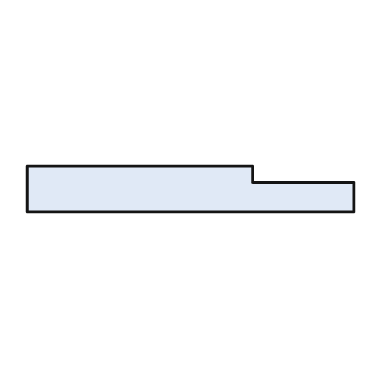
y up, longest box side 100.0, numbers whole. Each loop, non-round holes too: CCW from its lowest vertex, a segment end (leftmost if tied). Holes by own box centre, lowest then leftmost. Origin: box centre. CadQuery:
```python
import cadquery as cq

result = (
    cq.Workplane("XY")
    .moveTo(-50.0, -7.0)
    .lineTo(50.0, -7.0)
    .lineTo(50.0, 2.0)
    .lineTo(19.0, 2.0)
    .lineTo(19.0, 7.0)
    .lineTo(-50.0, 7.0)
    .close()
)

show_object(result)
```